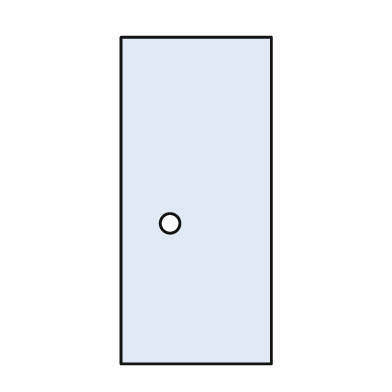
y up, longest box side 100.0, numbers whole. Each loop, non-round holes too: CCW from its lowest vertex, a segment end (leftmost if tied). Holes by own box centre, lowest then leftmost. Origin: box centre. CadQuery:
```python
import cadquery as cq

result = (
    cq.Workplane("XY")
    .moveTo(-23.0, -50.0)
    .lineTo(23.0, -50.0)
    .lineTo(23.0, 50.0)
    .lineTo(-23.0, 50.0)
    .close()
    .moveTo(-8.0, -7.0)
    .circle(3.0)
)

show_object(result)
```